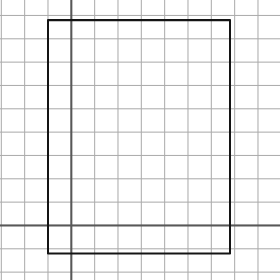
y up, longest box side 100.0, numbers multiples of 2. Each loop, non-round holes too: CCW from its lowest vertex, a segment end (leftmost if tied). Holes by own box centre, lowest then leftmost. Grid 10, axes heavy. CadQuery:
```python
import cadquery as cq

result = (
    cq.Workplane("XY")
    .moveTo(-10.0, -12.0)
    .lineTo(68.0, -12.0)
    .lineTo(68.0, 88.0)
    .lineTo(-10.0, 88.0)
    .close()
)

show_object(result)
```